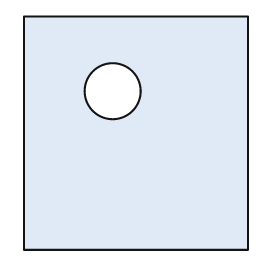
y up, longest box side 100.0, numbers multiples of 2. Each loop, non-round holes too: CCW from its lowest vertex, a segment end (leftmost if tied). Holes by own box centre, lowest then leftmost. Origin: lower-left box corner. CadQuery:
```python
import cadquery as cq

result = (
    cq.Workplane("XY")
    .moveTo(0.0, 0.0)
    .lineTo(96.0, 0.0)
    .lineTo(96.0, 100.0)
    .lineTo(0.0, 100.0)
    .close()
    .moveTo(38.0, 68.0)
    .circle(12.0)
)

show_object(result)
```